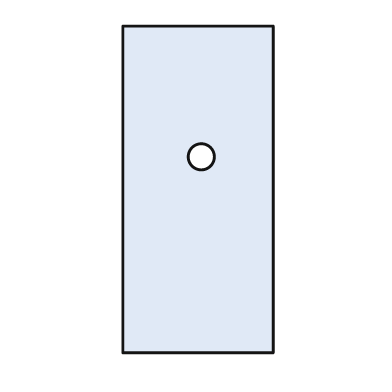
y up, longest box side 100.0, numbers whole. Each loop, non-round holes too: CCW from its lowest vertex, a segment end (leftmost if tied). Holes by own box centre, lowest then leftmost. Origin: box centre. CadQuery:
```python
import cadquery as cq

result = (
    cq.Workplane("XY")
    .moveTo(-23.0, -50.0)
    .lineTo(23.0, -50.0)
    .lineTo(23.0, 50.0)
    .lineTo(-23.0, 50.0)
    .close()
    .moveTo(1.0, 10.0)
    .circle(4.0)
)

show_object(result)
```